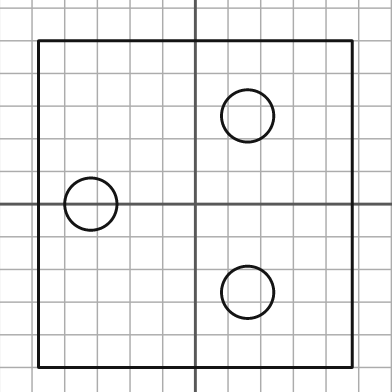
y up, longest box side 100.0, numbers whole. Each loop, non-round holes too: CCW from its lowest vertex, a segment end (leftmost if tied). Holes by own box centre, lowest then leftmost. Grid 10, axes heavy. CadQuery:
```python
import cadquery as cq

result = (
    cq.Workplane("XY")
    .moveTo(-48.0, -50.0)
    .lineTo(48.0, -50.0)
    .lineTo(48.0, 50.0)
    .lineTo(-48.0, 50.0)
    .close()
    .moveTo(16.0, -27.0)
    .circle(8.0)
    .moveTo(-32.0, 0.0)
    .circle(8.0)
    .moveTo(16.0, 27.0)
    .circle(8.0)
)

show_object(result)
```